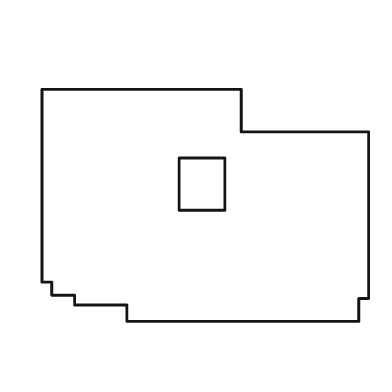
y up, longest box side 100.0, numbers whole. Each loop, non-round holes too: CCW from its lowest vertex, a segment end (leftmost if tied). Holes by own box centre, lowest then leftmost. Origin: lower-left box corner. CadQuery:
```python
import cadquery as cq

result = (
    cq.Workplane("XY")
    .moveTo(26.0, 0.0)
    .lineTo(97.0, 0.0)
    .lineTo(97.0, 7.0)
    .lineTo(100.0, 7.0)
    .lineTo(100.0, 58.0)
    .lineTo(61.0, 58.0)
    .lineTo(61.0, 71.0)
    .lineTo(0.0, 71.0)
    .lineTo(0.0, 12.0)
    .lineTo(3.0, 12.0)
    .lineTo(3.0, 8.0)
    .lineTo(10.0, 8.0)
    .lineTo(10.0, 5.0)
    .lineTo(26.0, 5.0)
    .close()
    .moveTo(42.0, 34.0)
    .lineTo(56.0, 34.0)
    .lineTo(56.0, 50.0)
    .lineTo(42.0, 50.0)
    .close()
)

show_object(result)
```